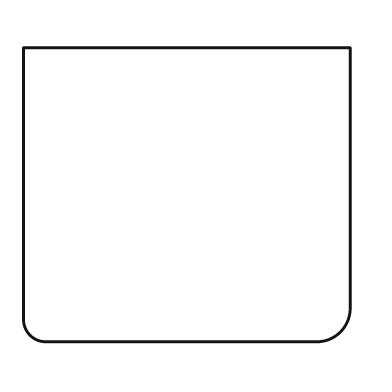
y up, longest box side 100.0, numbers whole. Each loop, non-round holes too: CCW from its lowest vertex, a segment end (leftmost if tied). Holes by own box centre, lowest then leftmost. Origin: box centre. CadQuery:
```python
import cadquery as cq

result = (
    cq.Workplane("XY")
    .moveTo(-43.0, -45.0)
    .lineTo(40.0, -45.0)
    .threePointArc((47.0, -42.0), (50.0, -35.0))
    .lineTo(50.0, 45.0)
    .lineTo(-50.0, 45.0)
    .lineTo(-50.0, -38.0)
    .threePointArc((-48.0, -43.0), (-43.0, -45.0))
    .close()
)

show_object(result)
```